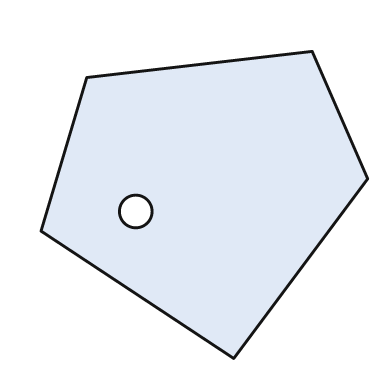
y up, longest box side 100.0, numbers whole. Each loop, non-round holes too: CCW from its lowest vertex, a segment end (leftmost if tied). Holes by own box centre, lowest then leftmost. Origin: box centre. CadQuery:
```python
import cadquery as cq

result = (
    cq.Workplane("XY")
    .moveTo(9.0, -47.0)
    .lineTo(50.0, 8.0)
    .lineTo(33.0, 47.0)
    .lineTo(-36.0, 39.0)
    .lineTo(-50.0, -8.0)
    .close()
    .moveTo(-21.0, -2.0)
    .circle(5.0)
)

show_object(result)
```